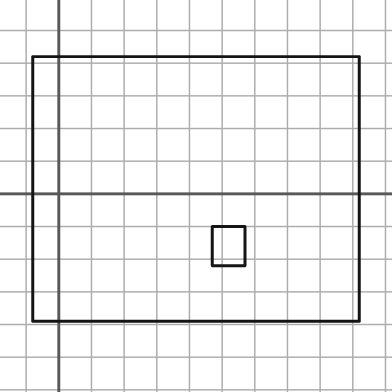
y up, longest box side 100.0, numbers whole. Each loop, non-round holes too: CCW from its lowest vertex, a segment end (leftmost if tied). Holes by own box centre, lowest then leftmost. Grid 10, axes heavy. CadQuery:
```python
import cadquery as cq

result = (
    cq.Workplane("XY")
    .moveTo(-8.0, -39.0)
    .lineTo(92.0, -39.0)
    .lineTo(92.0, 42.0)
    .lineTo(-8.0, 42.0)
    .close()
    .moveTo(47.0, -22.0)
    .lineTo(57.0, -22.0)
    .lineTo(57.0, -10.0)
    .lineTo(47.0, -10.0)
    .close()
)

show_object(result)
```